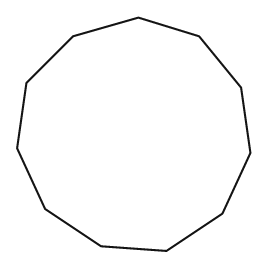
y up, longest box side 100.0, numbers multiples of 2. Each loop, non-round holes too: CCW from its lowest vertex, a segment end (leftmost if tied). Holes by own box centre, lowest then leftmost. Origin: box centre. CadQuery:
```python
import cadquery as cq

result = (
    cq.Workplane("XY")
    .moveTo(14.0, -50.0)
    .lineTo(38.0, -34.0)
    .lineTo(50.0, -8.0)
    .lineTo(46.0, 20.0)
    .lineTo(28.0, 42.0)
    .lineTo(2.0, 50.0)
    .lineTo(-26.0, 42.0)
    .lineTo(-46.0, 22.0)
    .lineTo(-50.0, -6.0)
    .lineTo(-38.0, -32.0)
    .lineTo(-14.0, -48.0)
    .close()
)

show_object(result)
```